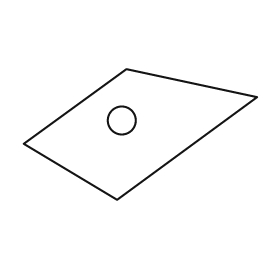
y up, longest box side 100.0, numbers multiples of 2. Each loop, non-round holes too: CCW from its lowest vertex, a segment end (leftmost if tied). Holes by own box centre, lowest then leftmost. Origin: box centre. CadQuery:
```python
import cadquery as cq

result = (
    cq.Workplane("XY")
    .moveTo(-10.0, -28.0)
    .lineTo(50.0, 16.0)
    .lineTo(-6.0, 28.0)
    .lineTo(-50.0, -4.0)
    .close()
    .moveTo(-8.0, 6.0)
    .circle(6.0)
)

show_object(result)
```